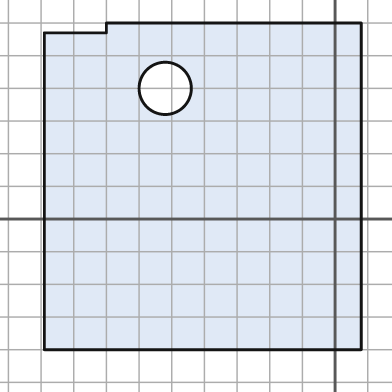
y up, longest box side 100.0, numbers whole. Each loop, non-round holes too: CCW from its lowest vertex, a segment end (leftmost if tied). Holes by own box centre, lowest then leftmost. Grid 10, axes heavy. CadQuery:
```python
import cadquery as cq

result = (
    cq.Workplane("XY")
    .moveTo(-89.0, -40.0)
    .lineTo(8.0, -40.0)
    .lineTo(8.0, 60.0)
    .lineTo(-70.0, 60.0)
    .lineTo(-70.0, 57.0)
    .lineTo(-89.0, 57.0)
    .close()
    .moveTo(-52.0, 40.0)
    .circle(8.0)
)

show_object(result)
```